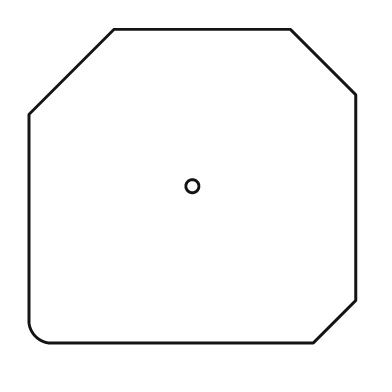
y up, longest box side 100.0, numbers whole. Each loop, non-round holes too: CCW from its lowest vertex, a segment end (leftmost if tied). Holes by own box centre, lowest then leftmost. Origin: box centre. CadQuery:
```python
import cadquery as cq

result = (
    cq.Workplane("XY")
    .moveTo(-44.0, -48.0)
    .lineTo(37.0, -48.0)
    .lineTo(50.0, -35.0)
    .lineTo(50.0, 28.0)
    .lineTo(30.0, 48.0)
    .lineTo(-24.0, 48.0)
    .lineTo(-50.0, 22.0)
    .lineTo(-50.0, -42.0)
    .threePointArc((-48.0, -46.0), (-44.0, -48.0))
    .close()
    .moveTo(0.0, 0.0)
    .circle(2.0)
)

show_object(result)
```